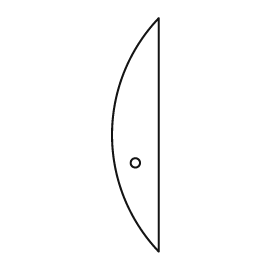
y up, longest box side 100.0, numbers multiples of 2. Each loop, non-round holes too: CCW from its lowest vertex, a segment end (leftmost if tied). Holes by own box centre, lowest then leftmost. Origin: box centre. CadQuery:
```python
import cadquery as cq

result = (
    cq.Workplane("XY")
    .moveTo(10.0, -50.0)
    .lineTo(10.0, 50.0)
    .threePointArc((-10.0, 0.0), (10.0, -50.0))
    .close()
    .moveTo(0.0, -12.0)
    .circle(2.0)
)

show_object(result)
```